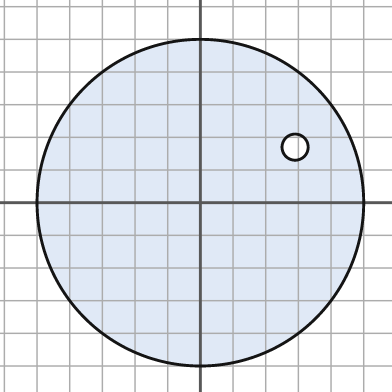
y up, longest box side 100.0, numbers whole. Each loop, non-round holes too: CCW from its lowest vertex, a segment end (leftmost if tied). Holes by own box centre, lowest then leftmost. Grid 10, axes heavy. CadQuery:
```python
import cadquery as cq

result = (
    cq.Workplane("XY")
    .moveTo(0.0, 0.0)
    .circle(50.0)
    .moveTo(29.0, 17.0)
    .circle(4.0)
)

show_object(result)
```